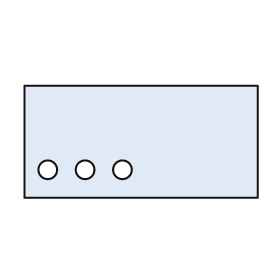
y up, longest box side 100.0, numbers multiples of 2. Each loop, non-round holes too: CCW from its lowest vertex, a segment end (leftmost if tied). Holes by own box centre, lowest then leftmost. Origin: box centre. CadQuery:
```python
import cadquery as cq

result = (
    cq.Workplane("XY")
    .moveTo(-50.0, -24.0)
    .lineTo(50.0, -24.0)
    .lineTo(50.0, 24.0)
    .lineTo(-50.0, 24.0)
    .close()
    .moveTo(-40.0, -12.0)
    .circle(4.0)
    .moveTo(-24.0, -12.0)
    .circle(4.0)
    .moveTo(-8.0, -12.0)
    .circle(4.0)
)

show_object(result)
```